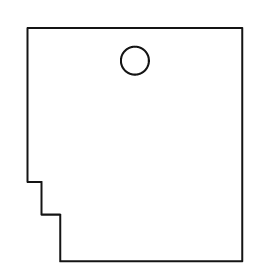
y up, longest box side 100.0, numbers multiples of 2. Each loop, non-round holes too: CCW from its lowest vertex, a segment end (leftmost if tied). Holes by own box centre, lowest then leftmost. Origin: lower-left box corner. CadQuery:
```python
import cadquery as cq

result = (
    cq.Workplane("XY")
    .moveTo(14.0, 0.0)
    .lineTo(92.0, 0.0)
    .lineTo(92.0, 100.0)
    .lineTo(0.0, 100.0)
    .lineTo(0.0, 34.0)
    .lineTo(6.0, 34.0)
    .lineTo(6.0, 20.0)
    .lineTo(14.0, 20.0)
    .close()
    .moveTo(46.0, 86.0)
    .circle(6.0)
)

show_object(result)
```